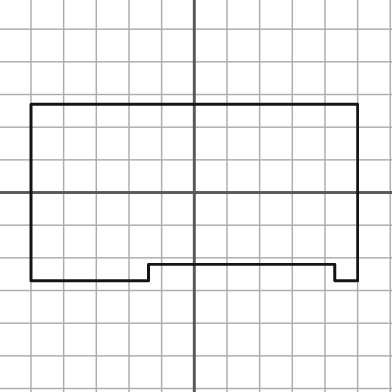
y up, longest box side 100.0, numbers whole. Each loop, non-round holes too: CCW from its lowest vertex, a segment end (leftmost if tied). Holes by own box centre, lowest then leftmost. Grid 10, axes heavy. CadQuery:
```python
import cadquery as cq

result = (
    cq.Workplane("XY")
    .moveTo(-50.0, -27.0)
    .lineTo(-14.0, -27.0)
    .lineTo(-14.0, -22.0)
    .lineTo(43.0, -22.0)
    .lineTo(43.0, -27.0)
    .lineTo(50.0, -27.0)
    .lineTo(50.0, 27.0)
    .lineTo(-50.0, 27.0)
    .close()
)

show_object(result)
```